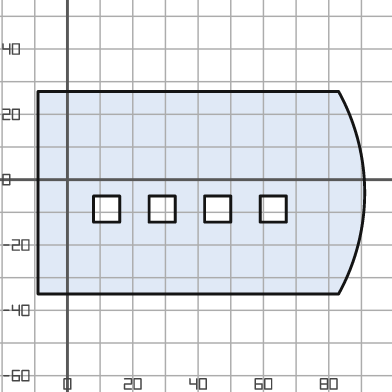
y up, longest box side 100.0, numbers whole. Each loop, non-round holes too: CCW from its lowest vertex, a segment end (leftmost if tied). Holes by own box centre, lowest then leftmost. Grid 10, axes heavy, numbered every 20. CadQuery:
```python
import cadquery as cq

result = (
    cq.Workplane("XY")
    .moveTo(-9.0, -35.0)
    .lineTo(83.0, -35.0)
    .threePointArc((91.0, -4.0), (83.0, 27.0))
    .lineTo(-9.0, 27.0)
    .close()
    .moveTo(8.0, -13.0)
    .lineTo(16.0, -13.0)
    .lineTo(16.0, -5.0)
    .lineTo(8.0, -5.0)
    .close()
    .moveTo(25.0, -13.0)
    .lineTo(33.0, -13.0)
    .lineTo(33.0, -5.0)
    .lineTo(25.0, -5.0)
    .close()
    .moveTo(42.0, -13.0)
    .lineTo(50.0, -13.0)
    .lineTo(50.0, -5.0)
    .lineTo(42.0, -5.0)
    .close()
    .moveTo(59.0, -13.0)
    .lineTo(67.0, -13.0)
    .lineTo(67.0, -5.0)
    .lineTo(59.0, -5.0)
    .close()
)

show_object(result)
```